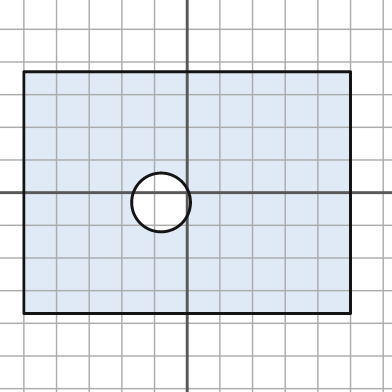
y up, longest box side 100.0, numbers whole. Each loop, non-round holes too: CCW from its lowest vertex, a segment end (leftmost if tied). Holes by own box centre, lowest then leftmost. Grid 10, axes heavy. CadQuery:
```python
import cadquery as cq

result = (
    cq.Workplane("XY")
    .moveTo(-50.0, -37.0)
    .lineTo(50.0, -37.0)
    .lineTo(50.0, 37.0)
    .lineTo(-50.0, 37.0)
    .close()
    .moveTo(-8.0, -3.0)
    .circle(9.0)
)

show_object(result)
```